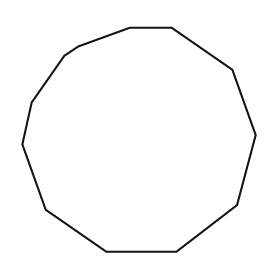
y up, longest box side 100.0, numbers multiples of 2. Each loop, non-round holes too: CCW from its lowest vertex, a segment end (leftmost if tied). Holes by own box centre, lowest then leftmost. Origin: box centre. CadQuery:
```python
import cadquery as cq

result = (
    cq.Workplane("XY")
    .moveTo(-14.0, -48.0)
    .lineTo(16.0, -48.0)
    .lineTo(42.0, -28.0)
    .lineTo(50.0, 2.0)
    .lineTo(40.0, 30.0)
    .lineTo(14.0, 48.0)
    .lineTo(-4.0, 48.0)
    .lineTo(-26.0, 40.0)
    .lineTo(-32.0, 36.0)
    .lineTo(-46.0, 16.0)
    .lineTo(-50.0, -2.0)
    .lineTo(-40.0, -30.0)
    .close()
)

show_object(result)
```